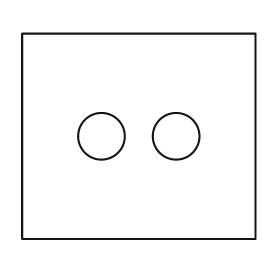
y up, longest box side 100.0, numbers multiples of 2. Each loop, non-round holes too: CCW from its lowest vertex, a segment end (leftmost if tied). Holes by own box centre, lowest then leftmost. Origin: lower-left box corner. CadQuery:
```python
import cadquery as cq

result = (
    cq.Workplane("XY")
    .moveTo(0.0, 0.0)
    .lineTo(100.0, 0.0)
    .lineTo(100.0, 88.0)
    .lineTo(0.0, 88.0)
    .close()
    .moveTo(34.0, 44.0)
    .circle(10.0)
    .moveTo(66.0, 44.0)
    .circle(10.0)
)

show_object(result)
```